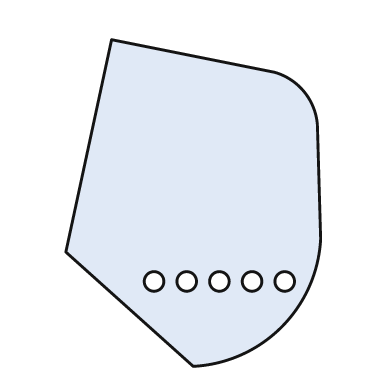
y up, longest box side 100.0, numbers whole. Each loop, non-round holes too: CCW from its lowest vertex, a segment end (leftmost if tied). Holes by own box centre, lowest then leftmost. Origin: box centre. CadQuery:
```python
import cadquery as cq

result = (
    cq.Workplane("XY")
    .moveTo(0.0, -50.0)
    .threePointArc((27.0, -38.0), (39.0, -11.0))
    .lineTo(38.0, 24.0)
    .threePointArc((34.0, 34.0), (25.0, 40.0))
    .lineTo(-25.0, 50.0)
    .lineTo(-39.0, -15.0)
    .close()
    .moveTo(-12.0, -24.0)
    .circle(3.0)
    .moveTo(-2.0, -24.0)
    .circle(3.0)
    .moveTo(8.0, -24.0)
    .circle(3.0)
    .moveTo(18.0, -24.0)
    .circle(3.0)
    .moveTo(28.0, -24.0)
    .circle(3.0)
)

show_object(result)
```